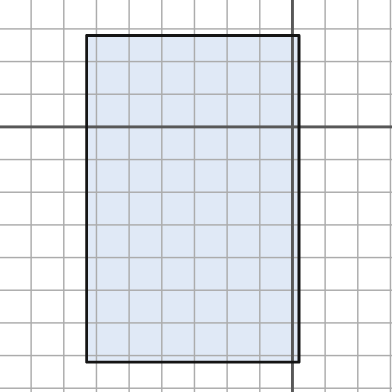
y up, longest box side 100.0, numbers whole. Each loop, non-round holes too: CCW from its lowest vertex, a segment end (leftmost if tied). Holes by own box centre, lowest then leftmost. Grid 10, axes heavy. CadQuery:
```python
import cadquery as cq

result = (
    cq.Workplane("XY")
    .moveTo(-63.0, -72.0)
    .lineTo(2.0, -72.0)
    .lineTo(2.0, 28.0)
    .lineTo(-63.0, 28.0)
    .close()
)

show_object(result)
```